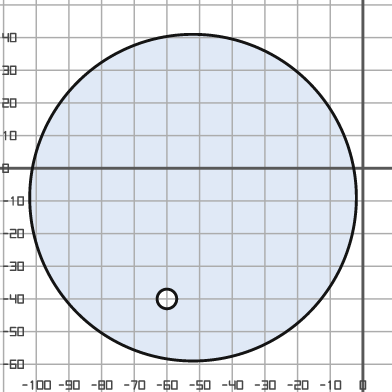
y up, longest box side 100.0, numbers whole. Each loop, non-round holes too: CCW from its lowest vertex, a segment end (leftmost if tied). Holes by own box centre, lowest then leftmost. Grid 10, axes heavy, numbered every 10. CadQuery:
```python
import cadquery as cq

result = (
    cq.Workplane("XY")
    .moveTo(-52.0, -9.0)
    .circle(50.0)
    .moveTo(-60.0, -40.0)
    .circle(3.0)
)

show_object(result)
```